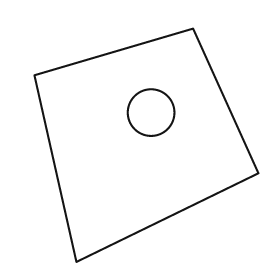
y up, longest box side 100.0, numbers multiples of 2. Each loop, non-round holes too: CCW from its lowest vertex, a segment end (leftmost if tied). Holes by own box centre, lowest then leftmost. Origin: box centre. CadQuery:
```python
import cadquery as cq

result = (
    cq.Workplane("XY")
    .moveTo(-30.0, -50.0)
    .lineTo(48.0, -12.0)
    .lineTo(20.0, 50.0)
    .lineTo(-48.0, 30.0)
    .close()
    .moveTo(2.0, 14.0)
    .circle(10.0)
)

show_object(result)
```